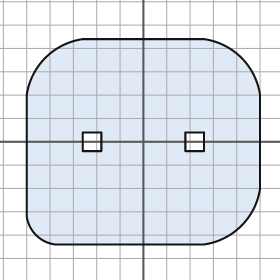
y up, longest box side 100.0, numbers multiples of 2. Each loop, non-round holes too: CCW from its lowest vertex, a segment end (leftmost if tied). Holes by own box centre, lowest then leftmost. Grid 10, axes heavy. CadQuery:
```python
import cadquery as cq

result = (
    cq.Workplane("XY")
    .moveTo(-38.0, -44.0)
    .lineTo(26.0, -44.0)
    .threePointArc((42.0, -36.0), (50.0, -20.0))
    .lineTo(50.0, 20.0)
    .threePointArc((42.0, 36.0), (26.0, 44.0))
    .lineTo(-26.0, 44.0)
    .threePointArc((-42.0, 36.0), (-50.0, 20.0))
    .lineTo(-50.0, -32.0)
    .threePointArc((-46.0, -40.0), (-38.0, -44.0))
    .close()
    .moveTo(-26.0, -4.0)
    .lineTo(-18.0, -4.0)
    .lineTo(-18.0, 4.0)
    .lineTo(-26.0, 4.0)
    .close()
    .moveTo(18.0, -4.0)
    .lineTo(26.0, -4.0)
    .lineTo(26.0, 4.0)
    .lineTo(18.0, 4.0)
    .close()
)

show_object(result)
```